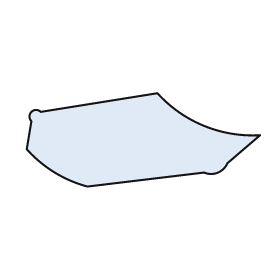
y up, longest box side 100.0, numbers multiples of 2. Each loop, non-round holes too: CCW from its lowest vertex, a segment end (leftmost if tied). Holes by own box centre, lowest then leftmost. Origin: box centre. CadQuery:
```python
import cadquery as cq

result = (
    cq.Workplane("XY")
    .moveTo(-24.0, -20.0)
    .lineTo(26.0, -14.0)
    .threePointArc((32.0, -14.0), (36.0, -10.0))
    .lineTo(50.0, 2.0)
    .threePointArc((26.0, 6.0), (6.0, 20.0))
    .lineTo(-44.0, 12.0)
    .threePointArc((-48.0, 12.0), (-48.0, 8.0))
    .lineTo(-50.0, -4.0)
    .threePointArc((-38.0, -14.0), (-24.0, -20.0))
    .close()
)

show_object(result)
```